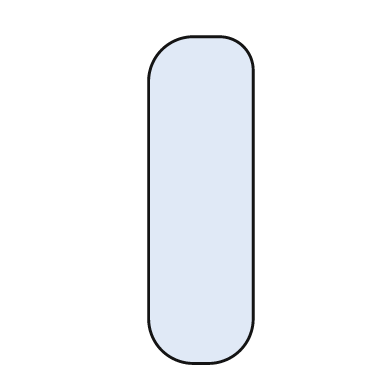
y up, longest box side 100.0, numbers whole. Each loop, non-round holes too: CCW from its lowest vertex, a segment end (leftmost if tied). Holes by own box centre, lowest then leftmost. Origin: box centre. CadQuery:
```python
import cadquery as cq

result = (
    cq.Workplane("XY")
    .moveTo(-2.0, -50.0)
    .lineTo(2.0, -50.0)
    .threePointArc((12.0, -46.0), (16.0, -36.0))
    .lineTo(16.0, 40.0)
    .threePointArc((13.0, 47.0), (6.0, 50.0))
    .lineTo(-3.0, 50.0)
    .threePointArc((-12.0, 46.0), (-16.0, 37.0))
    .lineTo(-16.0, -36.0)
    .threePointArc((-12.0, -46.0), (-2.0, -50.0))
    .close()
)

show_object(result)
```